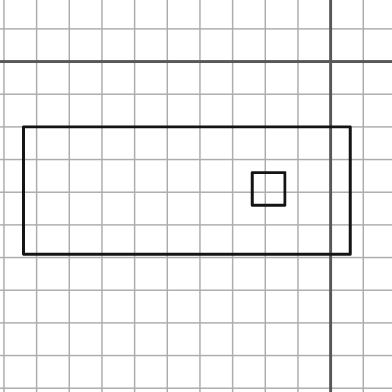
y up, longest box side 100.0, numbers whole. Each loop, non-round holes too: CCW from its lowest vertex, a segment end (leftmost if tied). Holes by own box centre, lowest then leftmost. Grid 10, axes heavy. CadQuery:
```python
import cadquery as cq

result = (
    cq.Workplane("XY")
    .moveTo(-94.0, -59.0)
    .lineTo(6.0, -59.0)
    .lineTo(6.0, -20.0)
    .lineTo(-94.0, -20.0)
    .close()
    .moveTo(-24.0, -44.0)
    .lineTo(-14.0, -44.0)
    .lineTo(-14.0, -34.0)
    .lineTo(-24.0, -34.0)
    .close()
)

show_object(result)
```